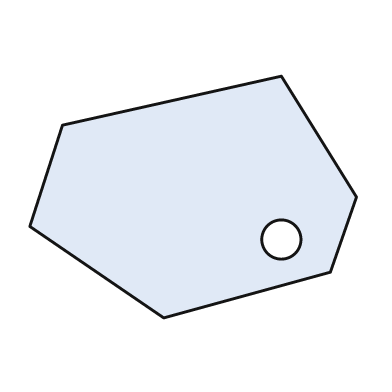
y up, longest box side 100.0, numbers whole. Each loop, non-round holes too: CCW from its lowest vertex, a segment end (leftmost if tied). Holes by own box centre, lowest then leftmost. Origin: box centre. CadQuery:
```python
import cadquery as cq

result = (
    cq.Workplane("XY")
    .moveTo(-9.0, -37.0)
    .lineTo(42.0, -23.0)
    .lineTo(50.0, 0.0)
    .lineTo(27.0, 37.0)
    .lineTo(-40.0, 22.0)
    .lineTo(-50.0, -9.0)
    .close()
    .moveTo(27.0, -13.0)
    .circle(6.0)
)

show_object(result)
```